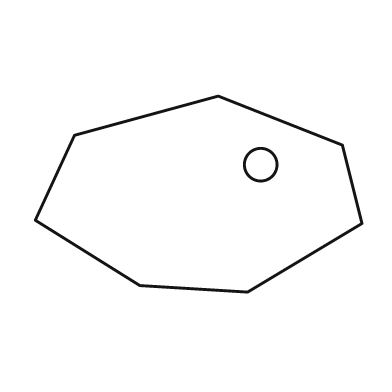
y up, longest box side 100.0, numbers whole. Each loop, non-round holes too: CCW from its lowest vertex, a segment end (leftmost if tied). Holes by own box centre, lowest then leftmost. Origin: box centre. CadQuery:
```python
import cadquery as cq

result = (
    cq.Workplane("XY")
    .moveTo(15.0, -30.0)
    .lineTo(50.0, -9.0)
    .lineTo(44.0, 15.0)
    .lineTo(6.0, 30.0)
    .lineTo(-38.0, 18.0)
    .lineTo(-50.0, -8.0)
    .lineTo(-18.0, -28.0)
    .close()
    .moveTo(19.0, 9.0)
    .circle(5.0)
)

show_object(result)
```